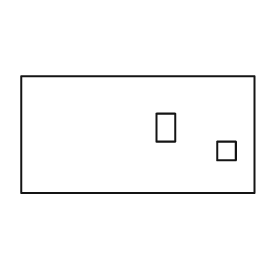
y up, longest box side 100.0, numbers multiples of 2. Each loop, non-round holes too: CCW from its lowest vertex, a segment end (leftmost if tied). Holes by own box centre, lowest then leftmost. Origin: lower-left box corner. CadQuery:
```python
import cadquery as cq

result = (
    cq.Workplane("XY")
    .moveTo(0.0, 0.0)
    .lineTo(100.0, 0.0)
    .lineTo(100.0, 50.0)
    .lineTo(0.0, 50.0)
    .close()
    .moveTo(84.0, 14.0)
    .lineTo(92.0, 14.0)
    .lineTo(92.0, 22.0)
    .lineTo(84.0, 22.0)
    .close()
    .moveTo(58.0, 22.0)
    .lineTo(66.0, 22.0)
    .lineTo(66.0, 34.0)
    .lineTo(58.0, 34.0)
    .close()
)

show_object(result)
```